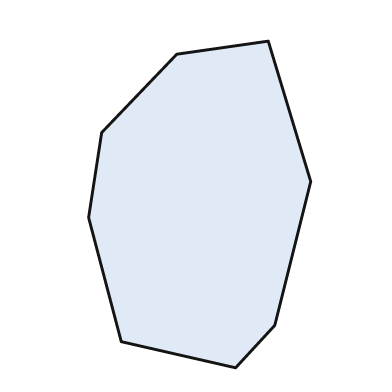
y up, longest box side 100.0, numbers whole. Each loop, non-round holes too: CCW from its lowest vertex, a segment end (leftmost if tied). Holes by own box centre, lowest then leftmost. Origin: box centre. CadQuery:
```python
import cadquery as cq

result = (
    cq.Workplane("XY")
    .moveTo(11.0, -50.0)
    .lineTo(23.0, -37.0)
    .lineTo(34.0, 7.0)
    .lineTo(21.0, 50.0)
    .lineTo(-7.0, 46.0)
    .lineTo(-30.0, 22.0)
    .lineTo(-34.0, -4.0)
    .lineTo(-24.0, -42.0)
    .close()
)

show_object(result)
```